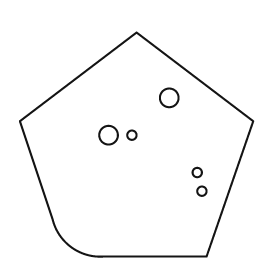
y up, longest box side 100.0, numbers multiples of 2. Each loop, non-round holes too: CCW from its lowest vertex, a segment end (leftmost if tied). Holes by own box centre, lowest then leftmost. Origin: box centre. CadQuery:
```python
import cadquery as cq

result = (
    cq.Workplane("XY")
    .moveTo(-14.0, -48.0)
    .lineTo(30.0, -48.0)
    .lineTo(50.0, 10.0)
    .lineTo(0.0, 48.0)
    .lineTo(-50.0, 10.0)
    .lineTo(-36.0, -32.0)
    .threePointArc((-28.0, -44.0), (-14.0, -48.0))
    .close()
    .moveTo(28.0, -20.0)
    .circle(2.0)
    .moveTo(26.0, -12.0)
    .circle(2.0)
    .moveTo(-12.0, 4.0)
    .circle(4.0)
    .moveTo(-2.0, 4.0)
    .circle(2.0)
    .moveTo(14.0, 20.0)
    .circle(4.0)
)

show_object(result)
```